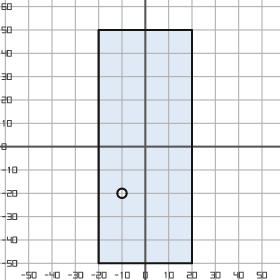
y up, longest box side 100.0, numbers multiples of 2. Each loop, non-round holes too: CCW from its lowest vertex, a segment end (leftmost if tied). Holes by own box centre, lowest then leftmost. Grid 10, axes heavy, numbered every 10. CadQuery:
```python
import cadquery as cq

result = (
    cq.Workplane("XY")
    .moveTo(-20.0, -50.0)
    .lineTo(20.0, -50.0)
    .lineTo(20.0, 50.0)
    .lineTo(-20.0, 50.0)
    .close()
    .moveTo(-10.0, -20.0)
    .circle(2.0)
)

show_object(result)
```